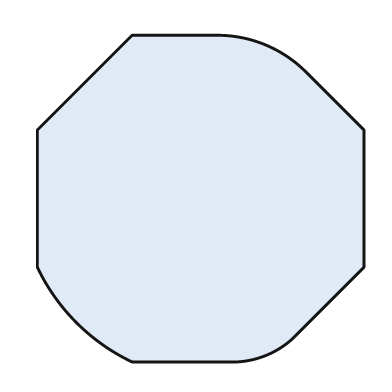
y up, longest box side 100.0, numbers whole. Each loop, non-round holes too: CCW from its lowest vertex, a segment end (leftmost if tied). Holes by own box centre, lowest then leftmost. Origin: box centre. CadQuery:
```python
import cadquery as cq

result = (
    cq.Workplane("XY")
    .moveTo(-21.0, -50.0)
    .lineTo(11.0, -50.0)
    .threePointArc((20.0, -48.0), (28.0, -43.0))
    .lineTo(50.0, -21.0)
    .lineTo(50.0, 21.0)
    .lineTo(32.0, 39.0)
    .threePointArc((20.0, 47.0), (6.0, 50.0))
    .lineTo(-21.0, 50.0)
    .lineTo(-50.0, 21.0)
    .lineTo(-50.0, -21.0)
    .threePointArc((-38.0, -38.0), (-21.0, -50.0))
    .close()
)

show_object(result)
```